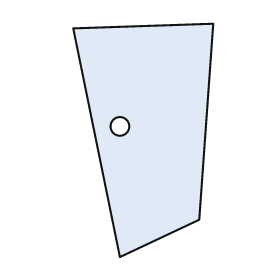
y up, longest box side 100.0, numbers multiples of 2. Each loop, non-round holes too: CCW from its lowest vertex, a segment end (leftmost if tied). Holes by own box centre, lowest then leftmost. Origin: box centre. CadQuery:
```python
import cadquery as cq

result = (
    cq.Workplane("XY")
    .moveTo(-10.0, -50.0)
    .lineTo(24.0, -34.0)
    .lineTo(30.0, 50.0)
    .lineTo(-30.0, 48.0)
    .close()
    .moveTo(-10.0, 6.0)
    .circle(4.0)
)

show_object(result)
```